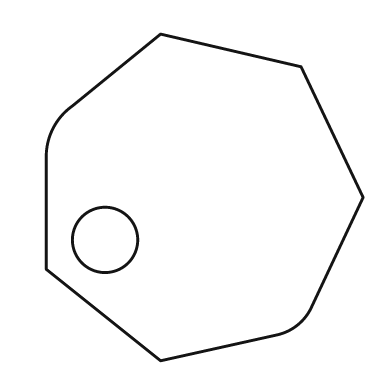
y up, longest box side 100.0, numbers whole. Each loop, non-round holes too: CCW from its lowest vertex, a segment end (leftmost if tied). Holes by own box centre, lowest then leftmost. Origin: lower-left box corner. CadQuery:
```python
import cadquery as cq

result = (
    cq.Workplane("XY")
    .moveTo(35.0, 0.0)
    .lineTo(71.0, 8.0)
    .threePointArc((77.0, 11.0), (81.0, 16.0))
    .lineTo(97.0, 50.0)
    .lineTo(78.0, 90.0)
    .lineTo(35.0, 100.0)
    .lineTo(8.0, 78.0)
    .threePointArc((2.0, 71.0), (0.0, 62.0))
    .lineTo(0.0, 28.0)
    .close()
    .moveTo(18.0, 37.0)
    .circle(10.0)
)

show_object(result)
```